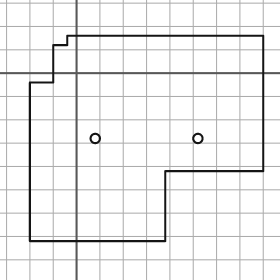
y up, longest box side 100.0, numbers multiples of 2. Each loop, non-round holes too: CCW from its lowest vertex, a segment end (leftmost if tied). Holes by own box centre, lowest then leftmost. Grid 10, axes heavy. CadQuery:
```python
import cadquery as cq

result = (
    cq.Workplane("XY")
    .moveTo(-20.0, -72.0)
    .lineTo(38.0, -72.0)
    .lineTo(38.0, -42.0)
    .lineTo(80.0, -42.0)
    .lineTo(80.0, 16.0)
    .lineTo(-4.0, 16.0)
    .lineTo(-4.0, 12.0)
    .lineTo(-10.0, 12.0)
    .lineTo(-10.0, -4.0)
    .lineTo(-20.0, -4.0)
    .close()
    .moveTo(8.0, -28.0)
    .circle(2.0)
    .moveTo(52.0, -28.0)
    .circle(2.0)
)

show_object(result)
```